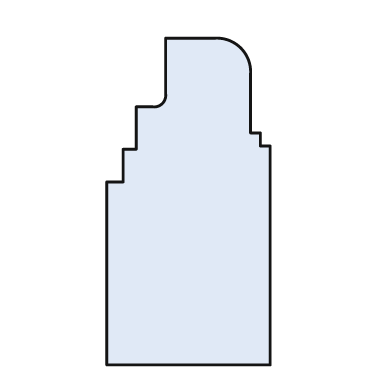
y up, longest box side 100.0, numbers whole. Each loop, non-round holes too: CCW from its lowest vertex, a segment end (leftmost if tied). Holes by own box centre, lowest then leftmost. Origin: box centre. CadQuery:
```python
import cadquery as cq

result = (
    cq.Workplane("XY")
    .moveTo(-25.0, -50.0)
    .lineTo(25.0, -50.0)
    .lineTo(25.0, 17.0)
    .lineTo(22.0, 17.0)
    .lineTo(22.0, 21.0)
    .lineTo(19.0, 21.0)
    .lineTo(19.0, 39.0)
    .threePointArc((16.0, 47.0), (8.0, 50.0))
    .lineTo(-7.0, 50.0)
    .lineTo(-7.0, 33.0)
    .threePointArc((-8.0, 30.0), (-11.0, 29.0))
    .lineTo(-16.0, 29.0)
    .lineTo(-16.0, 16.0)
    .lineTo(-20.0, 16.0)
    .lineTo(-20.0, 6.0)
    .lineTo(-25.0, 6.0)
    .close()
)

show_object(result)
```